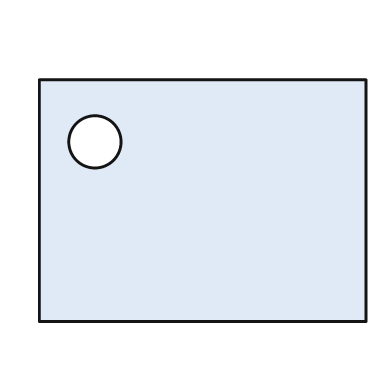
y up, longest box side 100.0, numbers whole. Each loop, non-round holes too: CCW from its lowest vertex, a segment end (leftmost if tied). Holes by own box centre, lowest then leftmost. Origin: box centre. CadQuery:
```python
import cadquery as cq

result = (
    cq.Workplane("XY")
    .moveTo(-50.0, -37.0)
    .lineTo(50.0, -37.0)
    .lineTo(50.0, 37.0)
    .lineTo(-50.0, 37.0)
    .close()
    .moveTo(-33.0, 18.0)
    .circle(8.0)
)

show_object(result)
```